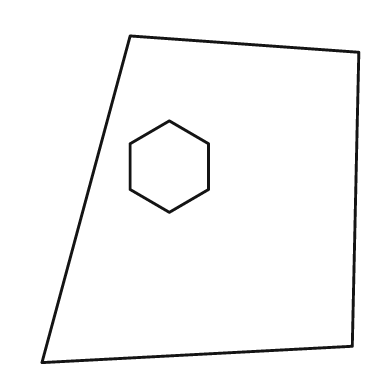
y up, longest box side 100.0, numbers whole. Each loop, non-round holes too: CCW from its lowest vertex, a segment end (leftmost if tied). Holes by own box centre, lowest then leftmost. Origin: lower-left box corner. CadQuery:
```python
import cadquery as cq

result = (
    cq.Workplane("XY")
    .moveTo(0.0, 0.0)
    .lineTo(95.0, 5.0)
    .lineTo(97.0, 95.0)
    .lineTo(27.0, 100.0)
    .close()
    .moveTo(39.0, 46.0)
    .lineTo(51.0, 53.0)
    .lineTo(51.0, 67.0)
    .lineTo(39.0, 74.0)
    .lineTo(27.0, 67.0)
    .lineTo(27.0, 53.0)
    .close()
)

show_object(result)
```